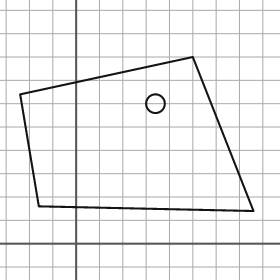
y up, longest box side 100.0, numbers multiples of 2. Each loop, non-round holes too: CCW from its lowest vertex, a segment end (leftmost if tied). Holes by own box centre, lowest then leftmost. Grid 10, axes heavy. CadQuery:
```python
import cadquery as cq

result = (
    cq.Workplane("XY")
    .moveTo(76.0, 14.0)
    .lineTo(50.0, 80.0)
    .lineTo(-24.0, 64.0)
    .lineTo(-16.0, 16.0)
    .close()
    .moveTo(34.0, 60.0)
    .circle(4.0)
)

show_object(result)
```